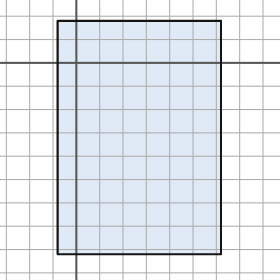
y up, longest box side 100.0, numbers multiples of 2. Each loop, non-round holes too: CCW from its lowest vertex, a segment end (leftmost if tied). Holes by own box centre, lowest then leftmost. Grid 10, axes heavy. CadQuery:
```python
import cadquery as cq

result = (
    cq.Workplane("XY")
    .moveTo(-8.0, -82.0)
    .lineTo(62.0, -82.0)
    .lineTo(62.0, 18.0)
    .lineTo(-8.0, 18.0)
    .close()
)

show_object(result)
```